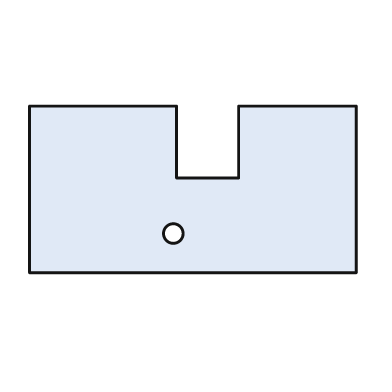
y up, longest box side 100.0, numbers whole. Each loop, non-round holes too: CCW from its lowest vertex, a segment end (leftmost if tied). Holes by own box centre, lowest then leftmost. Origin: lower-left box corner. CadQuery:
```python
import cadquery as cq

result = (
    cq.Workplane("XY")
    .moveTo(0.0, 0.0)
    .lineTo(100.0, 0.0)
    .lineTo(100.0, 51.0)
    .lineTo(64.0, 51.0)
    .lineTo(64.0, 29.0)
    .lineTo(45.0, 29.0)
    .lineTo(45.0, 51.0)
    .lineTo(0.0, 51.0)
    .close()
    .moveTo(44.0, 12.0)
    .circle(3.0)
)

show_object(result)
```